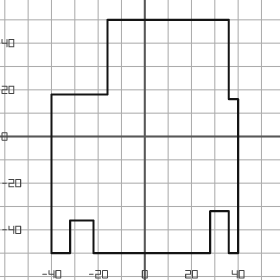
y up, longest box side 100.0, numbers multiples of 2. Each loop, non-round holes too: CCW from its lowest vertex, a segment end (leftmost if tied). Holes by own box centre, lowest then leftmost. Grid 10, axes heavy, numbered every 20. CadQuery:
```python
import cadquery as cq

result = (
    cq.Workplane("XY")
    .moveTo(-40.0, -50.0)
    .lineTo(-32.0, -50.0)
    .lineTo(-32.0, -36.0)
    .lineTo(-22.0, -36.0)
    .lineTo(-22.0, -50.0)
    .lineTo(28.0, -50.0)
    .lineTo(28.0, -32.0)
    .lineTo(36.0, -32.0)
    .lineTo(36.0, -50.0)
    .lineTo(40.0, -50.0)
    .lineTo(40.0, 16.0)
    .lineTo(36.0, 16.0)
    .lineTo(36.0, 50.0)
    .lineTo(-16.0, 50.0)
    .lineTo(-16.0, 18.0)
    .lineTo(-40.0, 18.0)
    .close()
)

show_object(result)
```